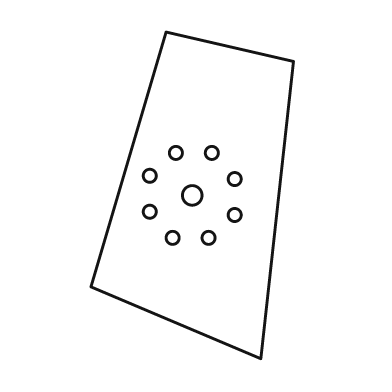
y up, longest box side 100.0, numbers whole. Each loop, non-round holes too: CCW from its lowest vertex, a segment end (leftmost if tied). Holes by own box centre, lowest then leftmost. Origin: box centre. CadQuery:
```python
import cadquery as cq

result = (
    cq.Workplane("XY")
    .moveTo(21.0, -50.0)
    .lineTo(31.0, 41.0)
    .lineTo(-8.0, 50.0)
    .lineTo(-31.0, -28.0)
    .close()
    .moveTo(-6.0, -13.0)
    .circle(2.0)
    .moveTo(5.0, -13.0)
    .circle(2.0)
    .moveTo(13.0, -6.0)
    .circle(2.0)
    .moveTo(-13.0, -5.0)
    .circle(2.0)
    .moveTo(0.0, 0.0)
    .circle(3.0)
    .moveTo(13.0, 5.0)
    .circle(2.0)
    .moveTo(-13.0, 6.0)
    .circle(2.0)
    .moveTo(-5.0, 13.0)
    .circle(2.0)
    .moveTo(6.0, 13.0)
    .circle(2.0)
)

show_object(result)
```